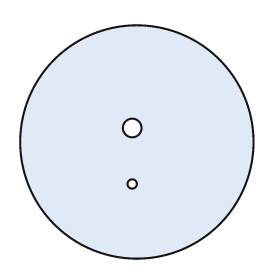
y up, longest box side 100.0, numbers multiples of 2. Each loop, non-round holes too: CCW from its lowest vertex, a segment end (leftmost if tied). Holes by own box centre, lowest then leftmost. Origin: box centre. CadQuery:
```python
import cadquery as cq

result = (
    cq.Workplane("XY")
    .moveTo(0.0, 0.0)
    .circle(50.0)
    .moveTo(-2.0, -18.0)
    .circle(2.0)
    .moveTo(-2.0, 6.0)
    .circle(4.0)
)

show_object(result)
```